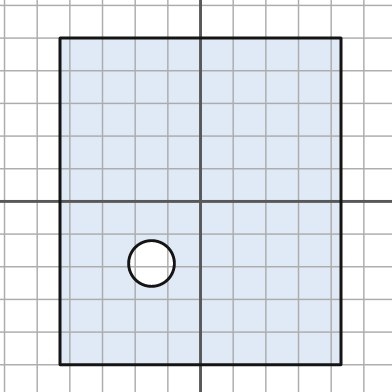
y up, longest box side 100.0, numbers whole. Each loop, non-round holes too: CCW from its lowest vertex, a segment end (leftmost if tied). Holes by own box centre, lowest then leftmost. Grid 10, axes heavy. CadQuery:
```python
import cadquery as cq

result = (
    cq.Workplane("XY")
    .moveTo(-43.0, -50.0)
    .lineTo(43.0, -50.0)
    .lineTo(43.0, 50.0)
    .lineTo(-43.0, 50.0)
    .close()
    .moveTo(-15.0, -19.0)
    .circle(7.0)
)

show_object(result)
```